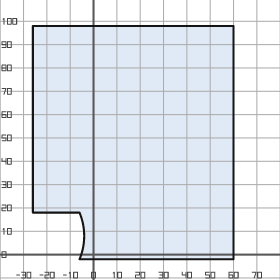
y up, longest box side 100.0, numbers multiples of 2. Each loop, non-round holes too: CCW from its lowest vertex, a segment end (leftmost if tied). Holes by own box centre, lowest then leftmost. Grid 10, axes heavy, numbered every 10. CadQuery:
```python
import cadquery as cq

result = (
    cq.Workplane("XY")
    .moveTo(-6.0, -2.0)
    .lineTo(60.0, -2.0)
    .lineTo(60.0, 98.0)
    .lineTo(-26.0, 98.0)
    .lineTo(-26.0, 18.0)
    .lineTo(-6.0, 18.0)
    .threePointArc((-4.0, 8.0), (-6.0, -2.0))
    .close()
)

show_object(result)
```